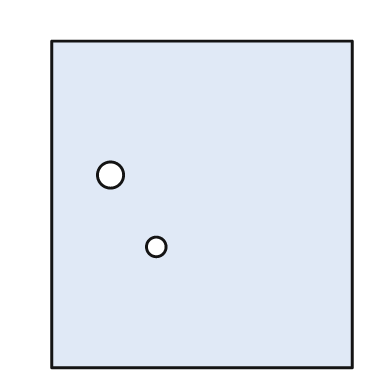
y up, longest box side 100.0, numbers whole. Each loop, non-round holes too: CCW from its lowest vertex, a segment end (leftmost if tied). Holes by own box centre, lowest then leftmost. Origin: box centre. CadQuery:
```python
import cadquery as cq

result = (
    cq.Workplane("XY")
    .moveTo(-46.0, -50.0)
    .lineTo(46.0, -50.0)
    .lineTo(46.0, 50.0)
    .lineTo(-46.0, 50.0)
    .close()
    .moveTo(-14.0, -13.0)
    .circle(3.0)
    .moveTo(-28.0, 9.0)
    .circle(4.0)
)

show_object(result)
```